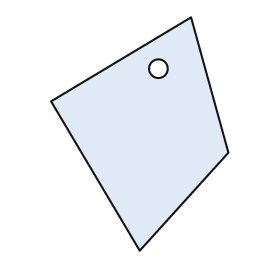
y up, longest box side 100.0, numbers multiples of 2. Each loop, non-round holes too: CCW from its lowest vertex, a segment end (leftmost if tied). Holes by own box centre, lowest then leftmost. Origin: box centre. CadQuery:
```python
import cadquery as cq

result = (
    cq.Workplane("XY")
    .moveTo(0.0, -50.0)
    .lineTo(38.0, -8.0)
    .lineTo(22.0, 50.0)
    .lineTo(-38.0, 14.0)
    .close()
    .moveTo(8.0, 28.0)
    .circle(4.0)
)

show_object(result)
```